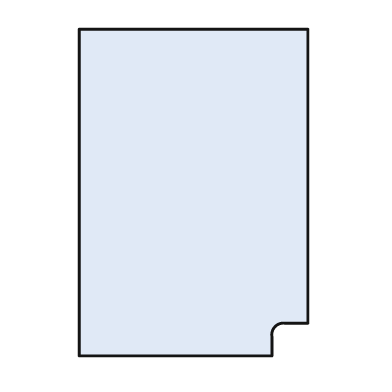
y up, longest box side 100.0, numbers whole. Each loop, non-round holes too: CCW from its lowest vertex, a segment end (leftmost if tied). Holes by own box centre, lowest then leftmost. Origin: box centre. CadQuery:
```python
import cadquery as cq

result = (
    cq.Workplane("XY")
    .moveTo(-35.0, -50.0)
    .lineTo(24.0, -50.0)
    .lineTo(24.0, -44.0)
    .threePointArc((25.0, -41.0), (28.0, -40.0))
    .lineTo(35.0, -40.0)
    .lineTo(35.0, 50.0)
    .lineTo(-35.0, 50.0)
    .close()
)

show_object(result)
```